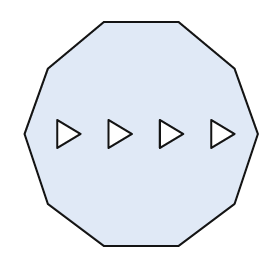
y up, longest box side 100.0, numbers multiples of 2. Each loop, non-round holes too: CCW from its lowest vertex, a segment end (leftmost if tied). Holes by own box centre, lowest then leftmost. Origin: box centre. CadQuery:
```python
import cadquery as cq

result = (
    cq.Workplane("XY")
    .moveTo(-16.0, -48.0)
    .lineTo(16.0, -48.0)
    .lineTo(40.0, -30.0)
    .lineTo(50.0, 0.0)
    .lineTo(40.0, 28.0)
    .lineTo(16.0, 48.0)
    .lineTo(-16.0, 48.0)
    .lineTo(-40.0, 28.0)
    .lineTo(-50.0, 0.0)
    .lineTo(-40.0, -30.0)
    .close()
    .moveTo(-36.0, -6.0)
    .lineTo(-26.0, 0.0)
    .lineTo(-36.0, 6.0)
    .close()
    .moveTo(-14.0, -6.0)
    .lineTo(-4.0, 0.0)
    .lineTo(-14.0, 6.0)
    .close()
    .moveTo(8.0, -6.0)
    .lineTo(18.0, 0.0)
    .lineTo(8.0, 6.0)
    .close()
    .moveTo(30.0, -6.0)
    .lineTo(40.0, 0.0)
    .lineTo(30.0, 6.0)
    .close()
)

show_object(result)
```